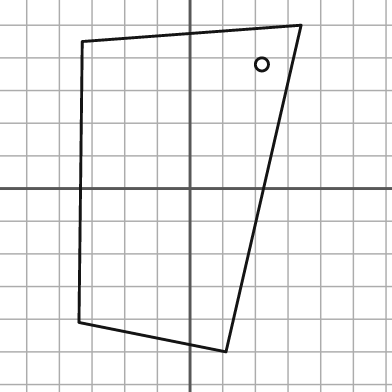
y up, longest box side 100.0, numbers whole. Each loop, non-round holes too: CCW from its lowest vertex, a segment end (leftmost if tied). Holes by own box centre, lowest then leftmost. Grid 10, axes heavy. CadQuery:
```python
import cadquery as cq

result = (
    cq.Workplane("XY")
    .moveTo(11.0, -50.0)
    .lineTo(34.0, 50.0)
    .lineTo(-33.0, 45.0)
    .lineTo(-34.0, -41.0)
    .close()
    .moveTo(22.0, 38.0)
    .circle(2.0)
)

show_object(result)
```